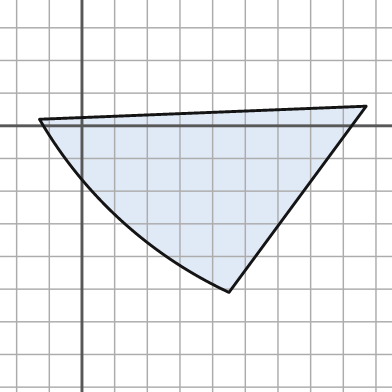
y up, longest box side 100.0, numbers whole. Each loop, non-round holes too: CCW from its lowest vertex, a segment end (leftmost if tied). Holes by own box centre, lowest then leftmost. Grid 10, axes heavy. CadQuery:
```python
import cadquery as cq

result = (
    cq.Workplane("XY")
    .moveTo(45.0, -51.0)
    .lineTo(87.0, 6.0)
    .lineTo(-13.0, 2.0)
    .threePointArc((12.0, -29.0), (45.0, -51.0))
    .close()
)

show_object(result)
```